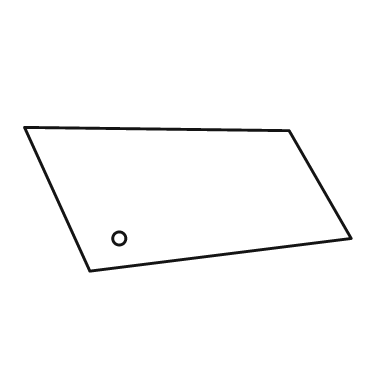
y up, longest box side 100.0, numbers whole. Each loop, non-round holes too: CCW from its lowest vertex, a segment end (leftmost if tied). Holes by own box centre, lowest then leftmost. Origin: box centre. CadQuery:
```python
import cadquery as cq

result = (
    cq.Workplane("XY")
    .moveTo(-30.0, -22.0)
    .lineTo(50.0, -12.0)
    .lineTo(31.0, 21.0)
    .lineTo(-50.0, 22.0)
    .close()
    .moveTo(-21.0, -12.0)
    .circle(2.0)
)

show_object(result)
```